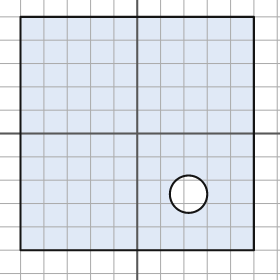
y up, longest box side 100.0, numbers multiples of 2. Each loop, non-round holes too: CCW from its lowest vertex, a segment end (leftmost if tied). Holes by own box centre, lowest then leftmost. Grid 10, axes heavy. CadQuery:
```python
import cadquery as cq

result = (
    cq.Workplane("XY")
    .moveTo(-50.0, -50.0)
    .lineTo(50.0, -50.0)
    .lineTo(50.0, 50.0)
    .lineTo(-50.0, 50.0)
    .close()
    .moveTo(22.0, -26.0)
    .circle(8.0)
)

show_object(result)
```